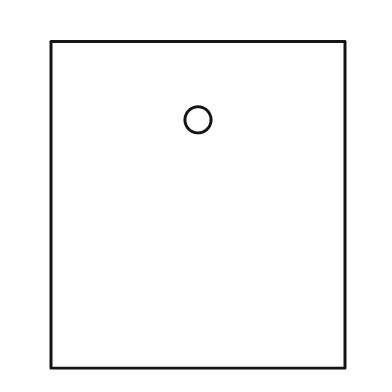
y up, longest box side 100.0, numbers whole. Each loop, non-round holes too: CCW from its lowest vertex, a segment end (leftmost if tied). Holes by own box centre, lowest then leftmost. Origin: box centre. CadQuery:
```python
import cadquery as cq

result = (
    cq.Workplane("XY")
    .moveTo(-45.0, -50.0)
    .lineTo(45.0, -50.0)
    .lineTo(45.0, 50.0)
    .lineTo(-45.0, 50.0)
    .close()
    .moveTo(0.0, 26.0)
    .circle(4.0)
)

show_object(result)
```